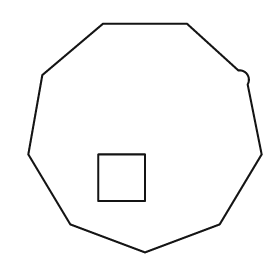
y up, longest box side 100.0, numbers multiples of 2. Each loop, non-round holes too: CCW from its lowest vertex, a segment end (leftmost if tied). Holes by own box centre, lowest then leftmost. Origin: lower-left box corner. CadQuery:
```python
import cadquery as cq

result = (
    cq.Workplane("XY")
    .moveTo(50.0, 0.0)
    .lineTo(82.0, 12.0)
    .lineTo(100.0, 42.0)
    .lineTo(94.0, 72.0)
    .threePointArc((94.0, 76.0), (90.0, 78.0))
    .lineTo(68.0, 98.0)
    .lineTo(32.0, 98.0)
    .lineTo(6.0, 76.0)
    .lineTo(0.0, 42.0)
    .lineTo(18.0, 12.0)
    .close()
    .moveTo(30.0, 22.0)
    .lineTo(50.0, 22.0)
    .lineTo(50.0, 42.0)
    .lineTo(30.0, 42.0)
    .close()
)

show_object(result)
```